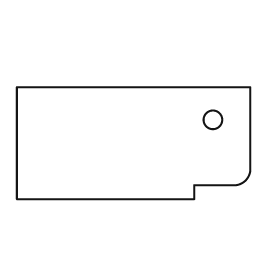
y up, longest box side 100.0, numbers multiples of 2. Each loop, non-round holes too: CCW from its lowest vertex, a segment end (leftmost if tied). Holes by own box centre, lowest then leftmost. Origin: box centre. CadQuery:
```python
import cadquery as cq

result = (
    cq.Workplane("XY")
    .moveTo(-50.0, -24.0)
    .lineTo(26.0, -24.0)
    .lineTo(26.0, -18.0)
    .lineTo(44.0, -18.0)
    .threePointArc((48.0, -16.0), (50.0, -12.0))
    .lineTo(50.0, 24.0)
    .lineTo(-50.0, 24.0)
    .close()
    .moveTo(34.0, 10.0)
    .circle(4.0)
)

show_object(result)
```